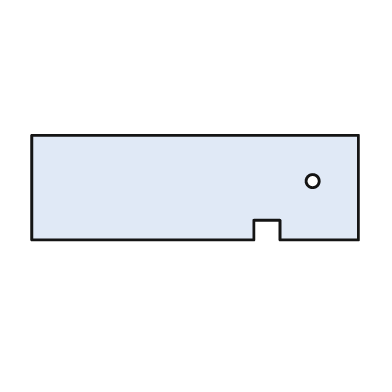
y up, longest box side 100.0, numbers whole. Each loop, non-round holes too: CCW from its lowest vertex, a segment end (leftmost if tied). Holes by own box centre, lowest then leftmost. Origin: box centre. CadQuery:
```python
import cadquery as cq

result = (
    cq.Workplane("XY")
    .moveTo(-50.0, -16.0)
    .lineTo(18.0, -16.0)
    .lineTo(18.0, -10.0)
    .lineTo(26.0, -10.0)
    .lineTo(26.0, -16.0)
    .lineTo(50.0, -16.0)
    .lineTo(50.0, 16.0)
    .lineTo(-50.0, 16.0)
    .close()
    .moveTo(36.0, 2.0)
    .circle(2.0)
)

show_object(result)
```